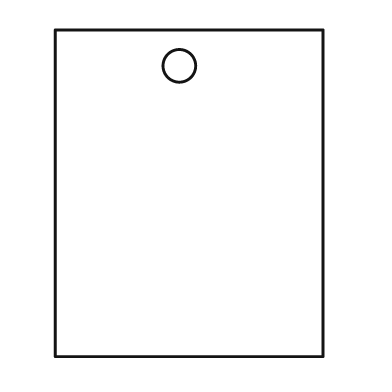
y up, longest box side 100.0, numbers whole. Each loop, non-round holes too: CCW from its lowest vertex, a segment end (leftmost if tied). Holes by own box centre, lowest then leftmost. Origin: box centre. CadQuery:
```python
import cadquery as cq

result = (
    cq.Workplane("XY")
    .moveTo(-41.0, -50.0)
    .lineTo(41.0, -50.0)
    .lineTo(41.0, 50.0)
    .lineTo(-41.0, 50.0)
    .close()
    .moveTo(-3.0, 39.0)
    .circle(5.0)
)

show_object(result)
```